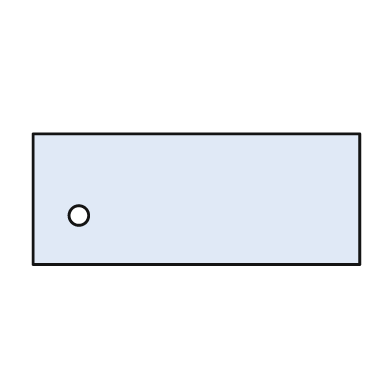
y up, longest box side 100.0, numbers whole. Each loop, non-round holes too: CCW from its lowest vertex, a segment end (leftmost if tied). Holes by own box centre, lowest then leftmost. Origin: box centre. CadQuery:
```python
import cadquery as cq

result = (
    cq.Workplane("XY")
    .moveTo(-50.0, -20.0)
    .lineTo(50.0, -20.0)
    .lineTo(50.0, 20.0)
    .lineTo(-50.0, 20.0)
    .close()
    .moveTo(-36.0, -5.0)
    .circle(3.0)
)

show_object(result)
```